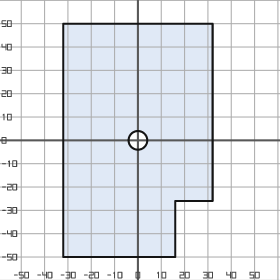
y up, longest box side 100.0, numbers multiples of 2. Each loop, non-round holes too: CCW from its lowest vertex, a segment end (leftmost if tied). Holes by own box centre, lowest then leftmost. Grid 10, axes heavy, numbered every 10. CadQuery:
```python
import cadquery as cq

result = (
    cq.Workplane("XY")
    .moveTo(-32.0, -50.0)
    .lineTo(16.0, -50.0)
    .lineTo(16.0, -26.0)
    .lineTo(32.0, -26.0)
    .lineTo(32.0, 50.0)
    .lineTo(-32.0, 50.0)
    .close()
    .moveTo(0.0, 0.0)
    .circle(4.0)
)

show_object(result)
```